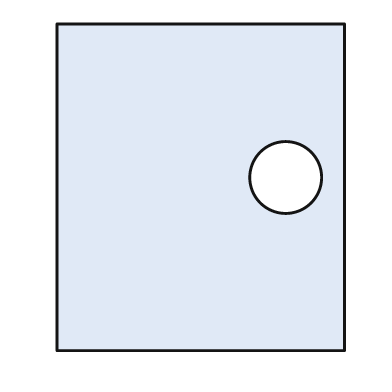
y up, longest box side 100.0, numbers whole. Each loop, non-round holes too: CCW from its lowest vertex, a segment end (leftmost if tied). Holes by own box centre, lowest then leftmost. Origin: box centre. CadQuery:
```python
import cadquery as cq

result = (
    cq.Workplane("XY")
    .moveTo(-44.0, -50.0)
    .lineTo(44.0, -50.0)
    .lineTo(44.0, 50.0)
    .lineTo(-44.0, 50.0)
    .close()
    .moveTo(26.0, 3.0)
    .circle(11.0)
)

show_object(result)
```